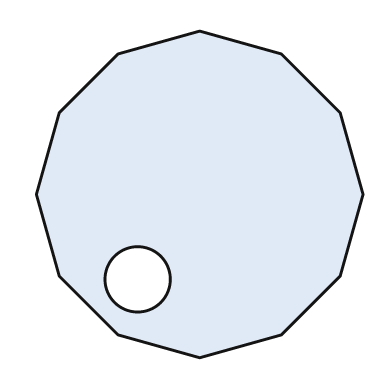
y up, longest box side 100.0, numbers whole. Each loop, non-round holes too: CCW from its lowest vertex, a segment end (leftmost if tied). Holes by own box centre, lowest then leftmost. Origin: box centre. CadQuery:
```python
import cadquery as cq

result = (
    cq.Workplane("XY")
    .moveTo(0.0, -50.0)
    .lineTo(25.0, -43.0)
    .lineTo(43.0, -25.0)
    .lineTo(50.0, 0.0)
    .lineTo(43.0, 25.0)
    .lineTo(25.0, 43.0)
    .lineTo(0.0, 50.0)
    .lineTo(-25.0, 43.0)
    .lineTo(-43.0, 25.0)
    .lineTo(-50.0, 0.0)
    .lineTo(-43.0, -25.0)
    .lineTo(-25.0, -43.0)
    .close()
    .moveTo(-19.0, -26.0)
    .circle(10.0)
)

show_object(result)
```